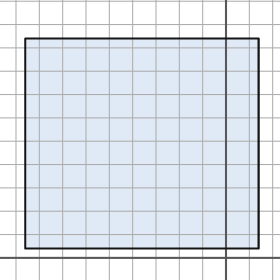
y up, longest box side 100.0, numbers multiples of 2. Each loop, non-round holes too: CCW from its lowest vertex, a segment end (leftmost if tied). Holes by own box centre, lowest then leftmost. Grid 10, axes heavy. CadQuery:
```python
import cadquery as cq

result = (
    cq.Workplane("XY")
    .moveTo(-86.0, 4.0)
    .lineTo(14.0, 4.0)
    .lineTo(14.0, 94.0)
    .lineTo(-86.0, 94.0)
    .close()
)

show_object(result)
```